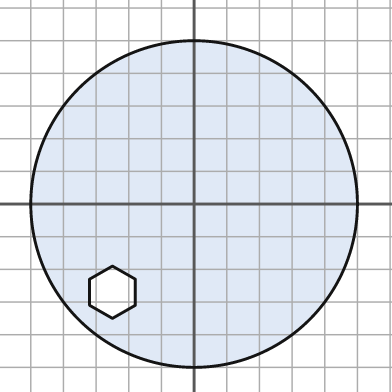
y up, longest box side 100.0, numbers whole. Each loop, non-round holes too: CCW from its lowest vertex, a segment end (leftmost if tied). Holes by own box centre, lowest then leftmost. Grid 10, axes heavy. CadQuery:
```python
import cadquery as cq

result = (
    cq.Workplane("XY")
    .moveTo(0.0, 0.0)
    .circle(50.0)
    .moveTo(-25.0, -35.0)
    .lineTo(-18.0, -31.0)
    .lineTo(-18.0, -23.0)
    .lineTo(-25.0, -19.0)
    .lineTo(-32.0, -23.0)
    .lineTo(-32.0, -31.0)
    .close()
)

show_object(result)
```